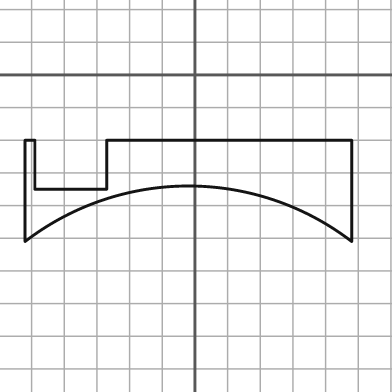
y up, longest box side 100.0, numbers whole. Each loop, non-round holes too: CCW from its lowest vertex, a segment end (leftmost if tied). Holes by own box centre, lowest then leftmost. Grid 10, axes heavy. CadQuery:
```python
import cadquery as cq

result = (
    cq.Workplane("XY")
    .moveTo(-52.0, -51.0)
    .threePointArc((-2.0, -34.0), (48.0, -51.0))
    .lineTo(48.0, -20.0)
    .lineTo(-27.0, -20.0)
    .lineTo(-27.0, -35.0)
    .lineTo(-49.0, -35.0)
    .lineTo(-49.0, -20.0)
    .lineTo(-52.0, -20.0)
    .close()
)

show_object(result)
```